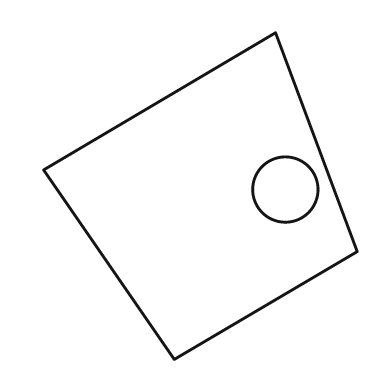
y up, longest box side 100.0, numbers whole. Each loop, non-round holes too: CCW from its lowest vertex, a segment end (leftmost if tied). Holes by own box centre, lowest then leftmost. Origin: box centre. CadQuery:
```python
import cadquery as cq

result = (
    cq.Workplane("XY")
    .moveTo(-8.0, -50.0)
    .lineTo(48.0, -17.0)
    .lineTo(23.0, 50.0)
    .lineTo(-48.0, 8.0)
    .close()
    .moveTo(26.0, 2.0)
    .circle(10.0)
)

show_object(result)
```